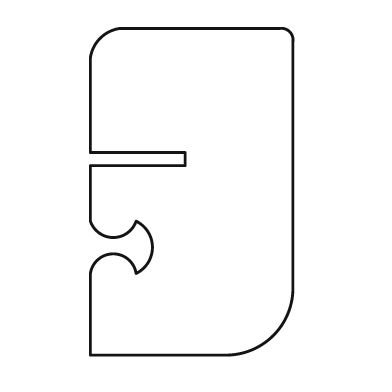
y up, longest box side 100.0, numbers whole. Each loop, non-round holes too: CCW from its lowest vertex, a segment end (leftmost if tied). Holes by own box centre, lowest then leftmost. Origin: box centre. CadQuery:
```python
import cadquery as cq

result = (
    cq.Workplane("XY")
    .moveTo(-31.0, -50.0)
    .lineTo(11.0, -50.0)
    .threePointArc((25.0, -44.0), (31.0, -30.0))
    .lineTo(31.0, 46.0)
    .threePointArc((30.0, 49.0), (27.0, 50.0))
    .lineTo(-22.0, 50.0)
    .threePointArc((-28.0, 47.0), (-31.0, 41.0))
    .lineTo(-31.0, 12.0)
    .lineTo(-2.0, 12.0)
    .lineTo(-2.0, 8.0)
    .lineTo(-31.0, 8.0)
    .lineTo(-31.0, -9.0)
    .threePointArc((-24.0, -14.0), (-17.0, -9.0))
    .threePointArc((-12.0, -17.0), (-17.0, -25.0))
    .threePointArc((-24.0, -19.0), (-31.0, -25.0))
    .close()
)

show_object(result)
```